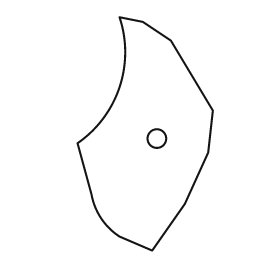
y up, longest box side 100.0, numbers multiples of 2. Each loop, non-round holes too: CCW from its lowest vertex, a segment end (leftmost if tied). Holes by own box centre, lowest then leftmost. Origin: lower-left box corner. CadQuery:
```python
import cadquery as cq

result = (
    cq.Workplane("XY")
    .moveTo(32.0, 0.0)
    .lineTo(46.0, 20.0)
    .lineTo(56.0, 42.0)
    .lineTo(58.0, 60.0)
    .lineTo(40.0, 90.0)
    .lineTo(28.0, 98.0)
    .lineTo(18.0, 100.0)
    .threePointArc((18.0, 70.0), (0.0, 46.0))
    .lineTo(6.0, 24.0)
    .threePointArc((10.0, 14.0), (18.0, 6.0))
    .close()
    .moveTo(34.0, 48.0)
    .circle(4.0)
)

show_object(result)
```